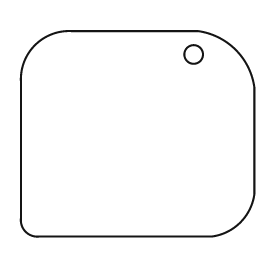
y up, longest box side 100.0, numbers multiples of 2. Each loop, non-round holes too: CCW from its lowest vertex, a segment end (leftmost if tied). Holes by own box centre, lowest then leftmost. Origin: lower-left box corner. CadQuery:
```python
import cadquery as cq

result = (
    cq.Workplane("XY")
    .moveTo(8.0, 0.0)
    .lineTo(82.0, 0.0)
    .threePointArc((94.0, 6.0), (100.0, 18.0))
    .lineTo(100.0, 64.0)
    .threePointArc((92.0, 80.0), (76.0, 88.0))
    .lineTo(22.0, 88.0)
    .threePointArc((6.0, 82.0), (0.0, 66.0))
    .lineTo(0.0, 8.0)
    .threePointArc((2.0, 2.0), (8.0, 0.0))
    .close()
    .moveTo(74.0, 78.0)
    .circle(4.0)
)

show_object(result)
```